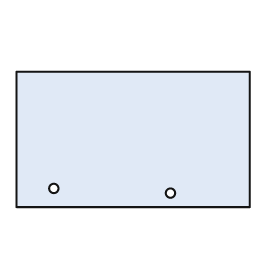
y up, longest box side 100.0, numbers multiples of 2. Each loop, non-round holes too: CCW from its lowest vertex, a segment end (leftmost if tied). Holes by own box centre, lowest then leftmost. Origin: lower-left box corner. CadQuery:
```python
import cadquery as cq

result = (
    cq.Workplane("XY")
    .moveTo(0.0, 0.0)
    .lineTo(100.0, 0.0)
    .lineTo(100.0, 58.0)
    .lineTo(0.0, 58.0)
    .close()
    .moveTo(66.0, 6.0)
    .circle(2.0)
    .moveTo(16.0, 8.0)
    .circle(2.0)
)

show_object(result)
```